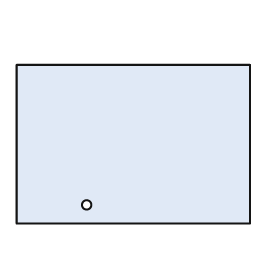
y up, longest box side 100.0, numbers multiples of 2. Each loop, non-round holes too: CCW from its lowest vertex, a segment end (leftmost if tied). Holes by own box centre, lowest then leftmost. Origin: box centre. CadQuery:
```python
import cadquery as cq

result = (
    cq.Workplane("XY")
    .moveTo(-50.0, -34.0)
    .lineTo(50.0, -34.0)
    .lineTo(50.0, 34.0)
    .lineTo(-50.0, 34.0)
    .close()
    .moveTo(-20.0, -26.0)
    .circle(2.0)
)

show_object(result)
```